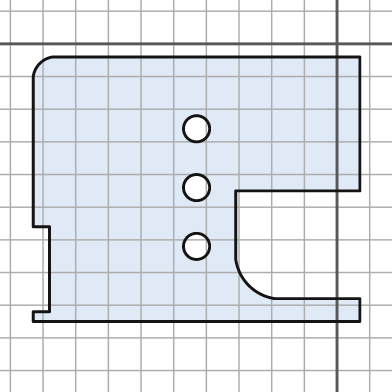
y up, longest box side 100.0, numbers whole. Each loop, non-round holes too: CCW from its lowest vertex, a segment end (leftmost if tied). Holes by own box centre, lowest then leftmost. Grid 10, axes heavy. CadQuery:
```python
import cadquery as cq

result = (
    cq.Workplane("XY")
    .moveTo(-93.0, -85.0)
    .lineTo(7.0, -85.0)
    .lineTo(7.0, -78.0)
    .lineTo(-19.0, -78.0)
    .threePointArc((-27.0, -74.0), (-31.0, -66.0))
    .lineTo(-31.0, -45.0)
    .lineTo(7.0, -45.0)
    .lineTo(7.0, -4.0)
    .lineTo(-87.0, -4.0)
    .threePointArc((-91.0, -6.0), (-93.0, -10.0))
    .lineTo(-93.0, -56.0)
    .lineTo(-88.0, -56.0)
    .lineTo(-88.0, -82.0)
    .lineTo(-93.0, -82.0)
    .close()
    .moveTo(-43.0, -62.0)
    .circle(4.0)
    .moveTo(-43.0, -44.0)
    .circle(4.0)
    .moveTo(-43.0, -26.0)
    .circle(4.0)
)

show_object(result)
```